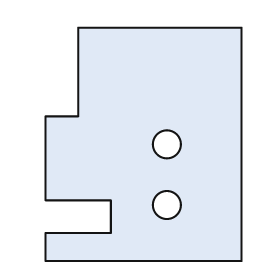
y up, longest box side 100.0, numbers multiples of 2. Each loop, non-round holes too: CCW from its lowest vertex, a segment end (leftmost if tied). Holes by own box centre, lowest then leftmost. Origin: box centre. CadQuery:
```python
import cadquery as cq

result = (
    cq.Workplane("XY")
    .moveTo(-42.0, -50.0)
    .lineTo(42.0, -50.0)
    .lineTo(42.0, 50.0)
    .lineTo(-28.0, 50.0)
    .lineTo(-28.0, 12.0)
    .lineTo(-42.0, 12.0)
    .lineTo(-42.0, -24.0)
    .lineTo(-14.0, -24.0)
    .lineTo(-14.0, -38.0)
    .lineTo(-42.0, -38.0)
    .close()
    .moveTo(10.0, -26.0)
    .circle(6.0)
    .moveTo(10.0, 0.0)
    .circle(6.0)
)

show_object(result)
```